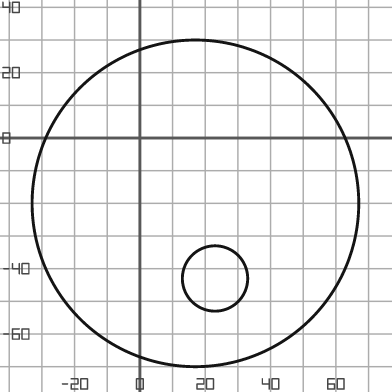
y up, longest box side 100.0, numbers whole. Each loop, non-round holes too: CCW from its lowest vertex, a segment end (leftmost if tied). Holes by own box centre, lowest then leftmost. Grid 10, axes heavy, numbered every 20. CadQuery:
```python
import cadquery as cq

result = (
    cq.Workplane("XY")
    .moveTo(17.0, -20.0)
    .circle(50.0)
    .moveTo(23.0, -43.0)
    .circle(10.0)
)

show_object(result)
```